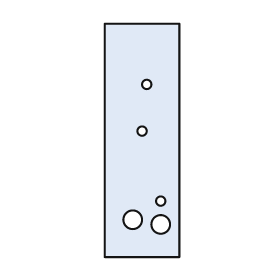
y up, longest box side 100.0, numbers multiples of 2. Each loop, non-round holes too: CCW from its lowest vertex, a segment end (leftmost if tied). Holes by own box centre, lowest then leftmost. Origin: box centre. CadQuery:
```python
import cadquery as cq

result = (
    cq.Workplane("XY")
    .moveTo(-16.0, -50.0)
    .lineTo(16.0, -50.0)
    .lineTo(16.0, 50.0)
    .lineTo(-16.0, 50.0)
    .close()
    .moveTo(8.0, -36.0)
    .circle(4.0)
    .moveTo(-4.0, -34.0)
    .circle(4.0)
    .moveTo(8.0, -26.0)
    .circle(2.0)
    .moveTo(0.0, 4.0)
    .circle(2.0)
    .moveTo(2.0, 24.0)
    .circle(2.0)
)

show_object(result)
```